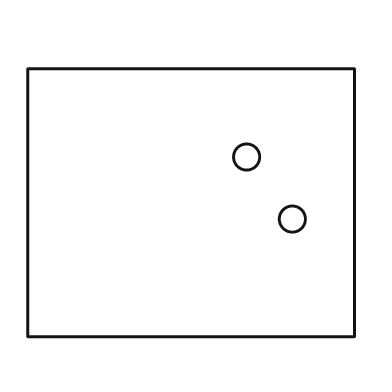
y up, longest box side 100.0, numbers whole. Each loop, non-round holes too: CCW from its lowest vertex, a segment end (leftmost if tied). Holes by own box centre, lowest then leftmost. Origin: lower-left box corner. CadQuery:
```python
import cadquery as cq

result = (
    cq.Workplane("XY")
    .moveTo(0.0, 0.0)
    .lineTo(100.0, 0.0)
    .lineTo(100.0, 82.0)
    .lineTo(0.0, 82.0)
    .close()
    .moveTo(81.0, 36.0)
    .circle(4.0)
    .moveTo(67.0, 55.0)
    .circle(4.0)
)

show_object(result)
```